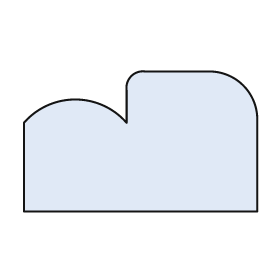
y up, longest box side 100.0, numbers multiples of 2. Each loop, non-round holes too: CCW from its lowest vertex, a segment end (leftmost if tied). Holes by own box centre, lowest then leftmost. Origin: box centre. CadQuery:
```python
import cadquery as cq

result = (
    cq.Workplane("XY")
    .moveTo(-50.0, -30.0)
    .lineTo(50.0, -30.0)
    .lineTo(50.0, 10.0)
    .threePointArc((44.0, 24.0), (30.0, 30.0))
    .lineTo(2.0, 30.0)
    .threePointArc((-4.0, 28.0), (-6.0, 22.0))
    .lineTo(-6.0, 8.0)
    .threePointArc((-28.0, 18.0), (-50.0, 8.0))
    .close()
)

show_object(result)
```